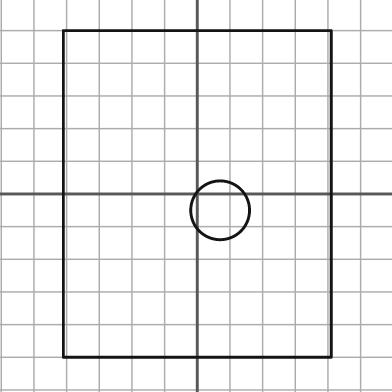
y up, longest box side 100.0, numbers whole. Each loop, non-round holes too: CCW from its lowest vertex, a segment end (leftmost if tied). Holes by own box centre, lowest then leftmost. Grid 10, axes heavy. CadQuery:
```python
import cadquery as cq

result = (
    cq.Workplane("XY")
    .moveTo(-41.0, -50.0)
    .lineTo(41.0, -50.0)
    .lineTo(41.0, 50.0)
    .lineTo(-41.0, 50.0)
    .close()
    .moveTo(7.0, -5.0)
    .circle(9.0)
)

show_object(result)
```